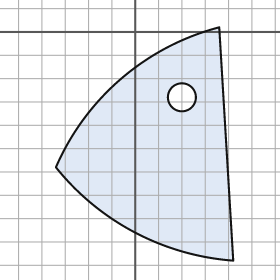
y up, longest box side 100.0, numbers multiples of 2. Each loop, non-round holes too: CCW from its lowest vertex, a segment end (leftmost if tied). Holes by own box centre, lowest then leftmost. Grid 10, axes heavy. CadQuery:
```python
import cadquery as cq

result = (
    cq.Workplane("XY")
    .moveTo(42.0, -98.0)
    .lineTo(36.0, 2.0)
    .threePointArc((-6.0, -20.0), (-34.0, -58.0))
    .threePointArc((0.0, -86.0), (42.0, -98.0))
    .close()
    .moveTo(20.0, -28.0)
    .circle(6.0)
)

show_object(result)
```